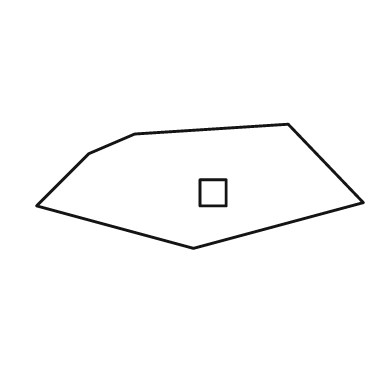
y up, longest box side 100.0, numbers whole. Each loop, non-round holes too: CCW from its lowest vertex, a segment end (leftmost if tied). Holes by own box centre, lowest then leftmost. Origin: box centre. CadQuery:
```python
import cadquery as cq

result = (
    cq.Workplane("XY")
    .moveTo(-2.0, -19.0)
    .lineTo(50.0, -5.0)
    .lineTo(27.0, 19.0)
    .lineTo(-20.0, 16.0)
    .lineTo(-34.0, 10.0)
    .lineTo(-50.0, -6.0)
    .close()
    .moveTo(0.0, -6.0)
    .lineTo(8.0, -6.0)
    .lineTo(8.0, 2.0)
    .lineTo(0.0, 2.0)
    .close()
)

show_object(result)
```